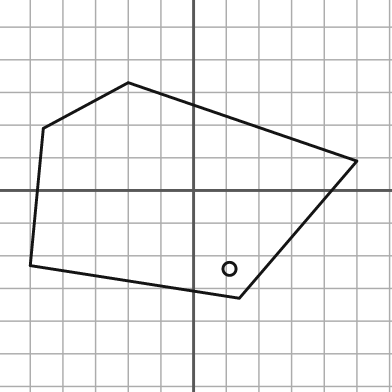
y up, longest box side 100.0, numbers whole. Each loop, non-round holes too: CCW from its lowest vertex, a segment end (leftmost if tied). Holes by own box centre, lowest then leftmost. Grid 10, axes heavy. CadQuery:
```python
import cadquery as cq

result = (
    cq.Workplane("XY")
    .moveTo(14.0, -33.0)
    .lineTo(50.0, 9.0)
    .lineTo(-20.0, 33.0)
    .lineTo(-46.0, 19.0)
    .lineTo(-50.0, -23.0)
    .close()
    .moveTo(11.0, -24.0)
    .circle(2.0)
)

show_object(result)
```